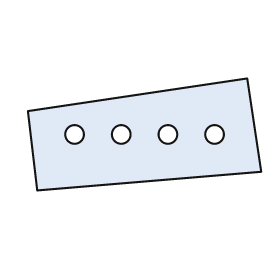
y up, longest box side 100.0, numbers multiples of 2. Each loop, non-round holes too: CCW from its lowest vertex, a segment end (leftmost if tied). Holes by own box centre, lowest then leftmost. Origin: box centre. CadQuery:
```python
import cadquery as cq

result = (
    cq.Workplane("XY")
    .moveTo(-46.0, -24.0)
    .lineTo(50.0, -16.0)
    .lineTo(44.0, 24.0)
    .lineTo(-50.0, 10.0)
    .close()
    .moveTo(-30.0, 0.0)
    .circle(4.0)
    .moveTo(-10.0, 0.0)
    .circle(4.0)
    .moveTo(10.0, 0.0)
    .circle(4.0)
    .moveTo(30.0, 0.0)
    .circle(4.0)
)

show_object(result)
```